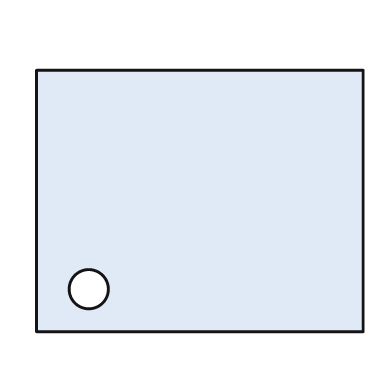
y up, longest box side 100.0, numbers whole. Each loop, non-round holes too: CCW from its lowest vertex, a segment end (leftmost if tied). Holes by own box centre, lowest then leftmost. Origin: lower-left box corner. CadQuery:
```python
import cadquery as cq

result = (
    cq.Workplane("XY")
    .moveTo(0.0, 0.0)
    .lineTo(100.0, 0.0)
    .lineTo(100.0, 80.0)
    .lineTo(0.0, 80.0)
    .close()
    .moveTo(16.0, 13.0)
    .circle(6.0)
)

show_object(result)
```